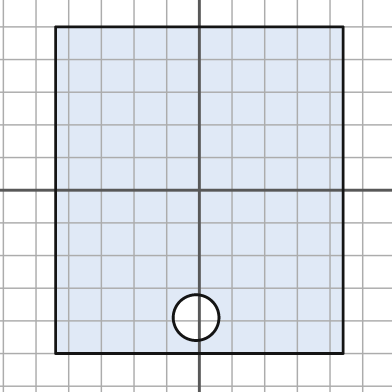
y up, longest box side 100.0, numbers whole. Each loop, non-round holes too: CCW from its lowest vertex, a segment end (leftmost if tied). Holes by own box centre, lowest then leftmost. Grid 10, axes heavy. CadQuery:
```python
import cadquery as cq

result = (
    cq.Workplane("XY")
    .moveTo(-44.0, -50.0)
    .lineTo(44.0, -50.0)
    .lineTo(44.0, 50.0)
    .lineTo(-44.0, 50.0)
    .close()
    .moveTo(-1.0, -39.0)
    .circle(7.0)
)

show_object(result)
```